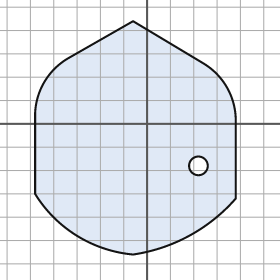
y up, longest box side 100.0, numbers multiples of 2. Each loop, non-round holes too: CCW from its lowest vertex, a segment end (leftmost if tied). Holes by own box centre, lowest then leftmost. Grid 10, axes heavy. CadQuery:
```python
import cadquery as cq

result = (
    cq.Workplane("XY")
    .moveTo(-6.0, -56.0)
    .threePointArc((18.0, -48.0), (38.0, -32.0))
    .lineTo(38.0, 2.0)
    .threePointArc((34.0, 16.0), (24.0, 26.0))
    .lineTo(-6.0, 44.0)
    .lineTo(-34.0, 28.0)
    .threePointArc((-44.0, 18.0), (-48.0, 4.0))
    .lineTo(-48.0, -30.0)
    .threePointArc((-30.0, -48.0), (-6.0, -56.0))
    .close()
    .moveTo(22.0, -18.0)
    .circle(4.0)
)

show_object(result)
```